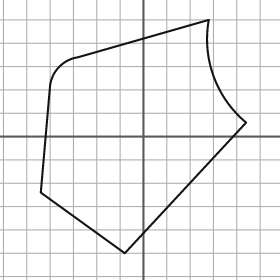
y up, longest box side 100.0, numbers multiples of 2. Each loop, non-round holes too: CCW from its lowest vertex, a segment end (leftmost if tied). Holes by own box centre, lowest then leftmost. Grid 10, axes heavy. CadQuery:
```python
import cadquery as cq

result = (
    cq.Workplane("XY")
    .moveTo(-8.0, -50.0)
    .lineTo(44.0, 6.0)
    .threePointArc((30.0, 26.0), (28.0, 50.0))
    .lineTo(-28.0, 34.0)
    .threePointArc((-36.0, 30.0), (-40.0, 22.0))
    .lineTo(-44.0, -24.0)
    .close()
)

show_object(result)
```